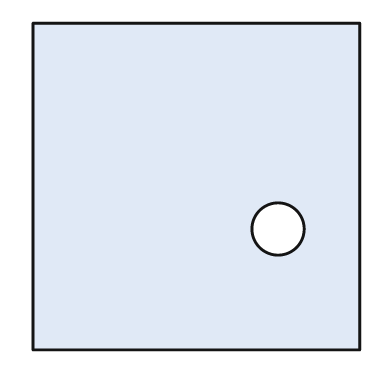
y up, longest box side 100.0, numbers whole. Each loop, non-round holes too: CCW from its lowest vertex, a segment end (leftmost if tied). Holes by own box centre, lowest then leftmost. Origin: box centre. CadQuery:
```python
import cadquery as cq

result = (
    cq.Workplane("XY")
    .moveTo(-50.0, -50.0)
    .lineTo(50.0, -50.0)
    .lineTo(50.0, 50.0)
    .lineTo(-50.0, 50.0)
    .close()
    .moveTo(25.0, -13.0)
    .circle(8.0)
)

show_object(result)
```